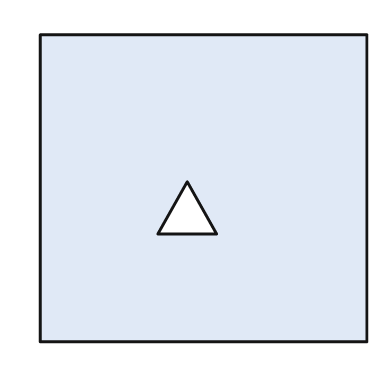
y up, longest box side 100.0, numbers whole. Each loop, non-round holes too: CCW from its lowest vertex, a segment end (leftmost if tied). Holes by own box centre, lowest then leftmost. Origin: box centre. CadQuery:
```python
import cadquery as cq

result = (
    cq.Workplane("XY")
    .moveTo(-50.0, -47.0)
    .lineTo(50.0, -47.0)
    .lineTo(50.0, 47.0)
    .lineTo(-50.0, 47.0)
    .close()
    .moveTo(-14.0, -14.0)
    .lineTo(4.0, -14.0)
    .lineTo(-5.0, 2.0)
    .close()
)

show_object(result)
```